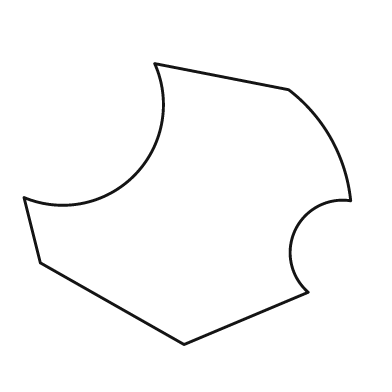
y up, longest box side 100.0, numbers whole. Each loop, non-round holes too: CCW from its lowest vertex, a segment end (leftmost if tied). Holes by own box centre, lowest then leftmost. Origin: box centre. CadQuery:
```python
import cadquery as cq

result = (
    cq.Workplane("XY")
    .moveTo(-1.0, -43.0)
    .lineTo(37.0, -27.0)
    .threePointArc((33.0, -8.0), (50.0, 1.0))
    .threePointArc((44.0, 20.0), (31.0, 35.0))
    .lineTo(-10.0, 43.0)
    .threePointArc((-16.0, 9.0), (-50.0, 2.0))
    .lineTo(-45.0, -18.0)
    .close()
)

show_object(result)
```